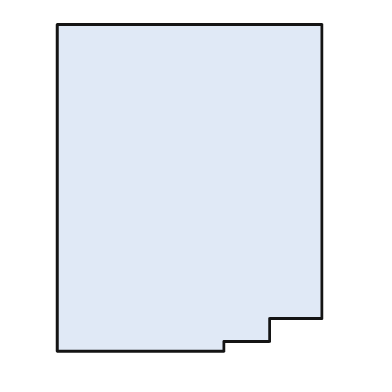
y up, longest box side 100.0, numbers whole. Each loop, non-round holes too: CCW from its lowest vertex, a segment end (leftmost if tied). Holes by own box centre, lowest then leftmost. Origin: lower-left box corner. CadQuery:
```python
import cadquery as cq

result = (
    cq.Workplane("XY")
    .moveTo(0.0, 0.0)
    .lineTo(51.0, 0.0)
    .lineTo(51.0, 3.0)
    .lineTo(65.0, 3.0)
    .lineTo(65.0, 10.0)
    .lineTo(81.0, 10.0)
    .lineTo(81.0, 100.0)
    .lineTo(0.0, 100.0)
    .close()
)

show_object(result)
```